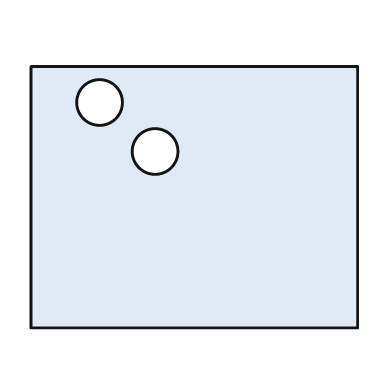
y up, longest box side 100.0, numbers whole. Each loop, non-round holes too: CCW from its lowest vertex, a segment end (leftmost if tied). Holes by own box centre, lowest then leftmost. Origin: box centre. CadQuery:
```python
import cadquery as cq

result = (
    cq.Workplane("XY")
    .moveTo(-50.0, -40.0)
    .lineTo(50.0, -40.0)
    .lineTo(50.0, 40.0)
    .lineTo(-50.0, 40.0)
    .close()
    .moveTo(-12.0, 14.0)
    .circle(7.0)
    .moveTo(-29.0, 29.0)
    .circle(7.0)
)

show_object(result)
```